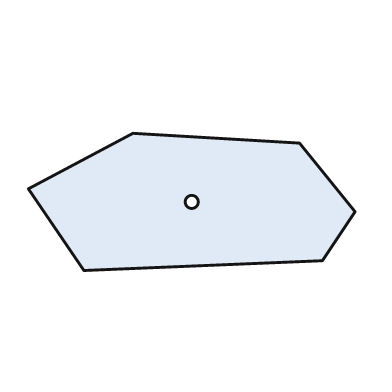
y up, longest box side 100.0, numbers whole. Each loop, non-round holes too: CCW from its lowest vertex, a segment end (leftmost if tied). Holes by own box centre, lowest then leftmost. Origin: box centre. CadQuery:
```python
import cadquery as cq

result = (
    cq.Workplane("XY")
    .moveTo(-33.0, -21.0)
    .lineTo(40.0, -18.0)
    .lineTo(50.0, -3.0)
    .lineTo(33.0, 18.0)
    .lineTo(-18.0, 21.0)
    .lineTo(-50.0, 4.0)
    .close()
    .moveTo(0.0, 0.0)
    .circle(2.0)
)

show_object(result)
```